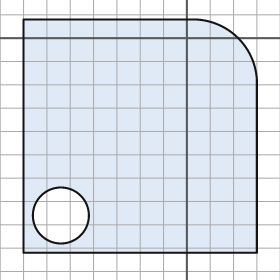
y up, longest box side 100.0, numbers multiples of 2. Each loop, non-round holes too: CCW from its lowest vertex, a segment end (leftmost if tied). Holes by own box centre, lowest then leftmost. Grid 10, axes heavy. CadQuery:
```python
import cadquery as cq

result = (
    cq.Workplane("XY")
    .moveTo(-70.0, -92.0)
    .lineTo(30.0, -92.0)
    .lineTo(30.0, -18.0)
    .threePointArc((22.0, 0.0), (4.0, 8.0))
    .lineTo(-70.0, 8.0)
    .close()
    .moveTo(-54.0, -76.0)
    .circle(12.0)
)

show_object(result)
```